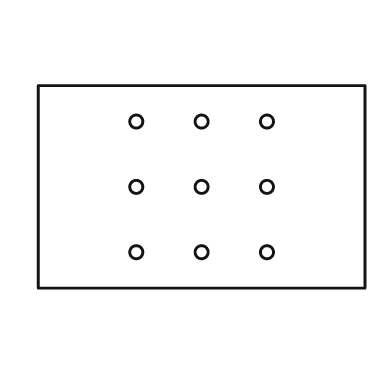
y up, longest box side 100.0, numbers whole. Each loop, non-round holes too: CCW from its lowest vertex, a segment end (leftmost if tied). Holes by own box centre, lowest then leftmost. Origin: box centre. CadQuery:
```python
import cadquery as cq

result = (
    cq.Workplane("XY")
    .moveTo(-50.0, -31.0)
    .lineTo(50.0, -31.0)
    .lineTo(50.0, 31.0)
    .lineTo(-50.0, 31.0)
    .close()
    .moveTo(-20.0, -20.0)
    .circle(2.0)
    .moveTo(0.0, -20.0)
    .circle(2.0)
    .moveTo(20.0, -20.0)
    .circle(2.0)
    .moveTo(-20.0, 0.0)
    .circle(2.0)
    .moveTo(0.0, 0.0)
    .circle(2.0)
    .moveTo(20.0, 0.0)
    .circle(2.0)
    .moveTo(-20.0, 20.0)
    .circle(2.0)
    .moveTo(0.0, 20.0)
    .circle(2.0)
    .moveTo(20.0, 20.0)
    .circle(2.0)
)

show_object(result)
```